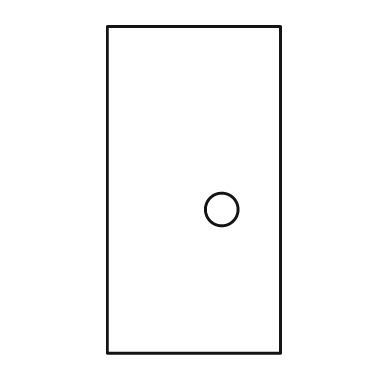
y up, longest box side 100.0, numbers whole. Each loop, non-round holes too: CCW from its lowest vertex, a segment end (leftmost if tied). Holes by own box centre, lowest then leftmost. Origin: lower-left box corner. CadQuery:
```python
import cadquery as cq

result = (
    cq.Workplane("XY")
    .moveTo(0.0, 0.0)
    .lineTo(53.0, 0.0)
    .lineTo(53.0, 100.0)
    .lineTo(0.0, 100.0)
    .close()
    .moveTo(35.0, 44.0)
    .circle(5.0)
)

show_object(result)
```